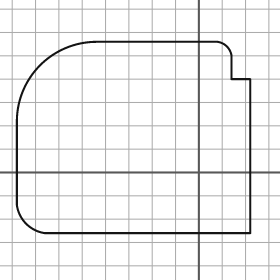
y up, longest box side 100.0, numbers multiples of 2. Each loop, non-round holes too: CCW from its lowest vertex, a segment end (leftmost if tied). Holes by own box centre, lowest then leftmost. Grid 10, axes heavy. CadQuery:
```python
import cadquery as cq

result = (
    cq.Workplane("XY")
    .moveTo(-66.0, -26.0)
    .lineTo(22.0, -26.0)
    .lineTo(22.0, 40.0)
    .lineTo(14.0, 40.0)
    .lineTo(14.0, 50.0)
    .threePointArc((12.0, 54.0), (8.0, 56.0))
    .lineTo(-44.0, 56.0)
    .threePointArc((-68.0, 46.0), (-78.0, 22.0))
    .lineTo(-78.0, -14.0)
    .threePointArc((-74.0, -22.0), (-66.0, -26.0))
    .close()
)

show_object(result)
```